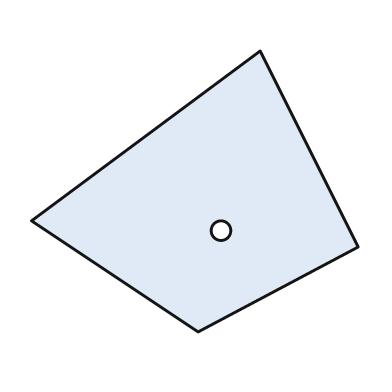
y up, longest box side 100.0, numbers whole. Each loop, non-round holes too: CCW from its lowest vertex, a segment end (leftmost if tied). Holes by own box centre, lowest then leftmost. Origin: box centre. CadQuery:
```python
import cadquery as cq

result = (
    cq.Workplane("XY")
    .moveTo(1.0, -43.0)
    .lineTo(50.0, -17.0)
    .lineTo(20.0, 43.0)
    .lineTo(-50.0, -9.0)
    .close()
    .moveTo(8.0, -12.0)
    .circle(3.0)
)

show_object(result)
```